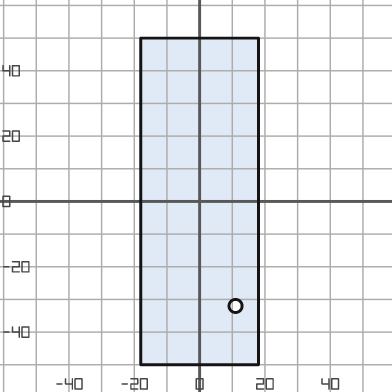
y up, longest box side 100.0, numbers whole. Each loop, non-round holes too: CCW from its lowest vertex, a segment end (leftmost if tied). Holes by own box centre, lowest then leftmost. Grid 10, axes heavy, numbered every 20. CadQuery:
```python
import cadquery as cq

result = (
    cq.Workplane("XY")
    .moveTo(-18.0, -50.0)
    .lineTo(18.0, -50.0)
    .lineTo(18.0, 50.0)
    .lineTo(-18.0, 50.0)
    .close()
    .moveTo(11.0, -32.0)
    .circle(2.0)
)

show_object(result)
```